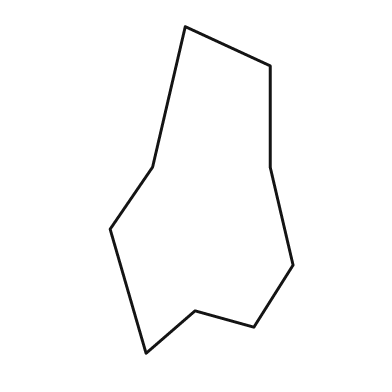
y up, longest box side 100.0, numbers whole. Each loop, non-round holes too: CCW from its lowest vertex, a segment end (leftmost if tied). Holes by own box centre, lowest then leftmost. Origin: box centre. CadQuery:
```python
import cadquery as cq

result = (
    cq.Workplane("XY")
    .moveTo(-17.0, -50.0)
    .lineTo(-2.0, -37.0)
    .lineTo(16.0, -42.0)
    .lineTo(28.0, -23.0)
    .lineTo(21.0, 7.0)
    .lineTo(21.0, 38.0)
    .lineTo(-5.0, 50.0)
    .lineTo(-15.0, 7.0)
    .lineTo(-28.0, -12.0)
    .close()
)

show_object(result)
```